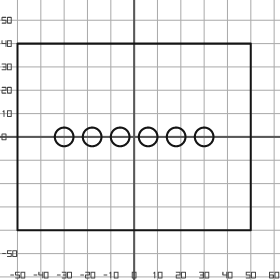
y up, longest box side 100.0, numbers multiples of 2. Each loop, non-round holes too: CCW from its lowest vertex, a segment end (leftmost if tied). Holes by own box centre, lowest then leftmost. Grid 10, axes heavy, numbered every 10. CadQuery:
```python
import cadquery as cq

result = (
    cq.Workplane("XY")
    .moveTo(-50.0, -40.0)
    .lineTo(50.0, -40.0)
    .lineTo(50.0, 40.0)
    .lineTo(-50.0, 40.0)
    .close()
    .moveTo(-30.0, 0.0)
    .circle(4.0)
    .moveTo(-18.0, 0.0)
    .circle(4.0)
    .moveTo(-6.0, 0.0)
    .circle(4.0)
    .moveTo(6.0, 0.0)
    .circle(4.0)
    .moveTo(18.0, 0.0)
    .circle(4.0)
    .moveTo(30.0, 0.0)
    .circle(4.0)
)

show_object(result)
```